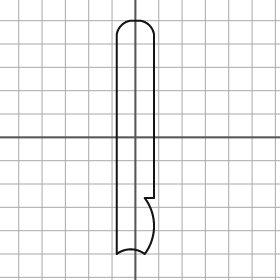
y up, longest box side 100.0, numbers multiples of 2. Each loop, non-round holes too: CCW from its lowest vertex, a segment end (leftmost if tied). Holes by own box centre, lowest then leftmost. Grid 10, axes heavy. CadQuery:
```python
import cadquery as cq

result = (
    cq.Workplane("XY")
    .moveTo(-8.0, -50.0)
    .threePointArc((-2.0, -48.0), (4.0, -50.0))
    .threePointArc((8.0, -38.0), (4.0, -26.0))
    .lineTo(8.0, -26.0)
    .lineTo(8.0, 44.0)
    .threePointArc((6.0, 48.0), (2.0, 50.0))
    .lineTo(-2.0, 50.0)
    .threePointArc((-6.0, 48.0), (-8.0, 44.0))
    .close()
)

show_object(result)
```